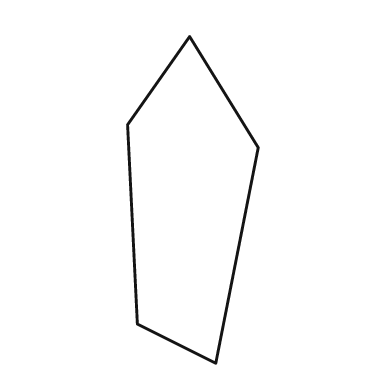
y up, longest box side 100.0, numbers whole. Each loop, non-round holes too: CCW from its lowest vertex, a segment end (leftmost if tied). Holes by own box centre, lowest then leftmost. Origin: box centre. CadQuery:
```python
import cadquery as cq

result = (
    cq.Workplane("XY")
    .moveTo(7.0, -50.0)
    .lineTo(20.0, 16.0)
    .lineTo(-1.0, 50.0)
    .lineTo(-20.0, 23.0)
    .lineTo(-17.0, -38.0)
    .close()
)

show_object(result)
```